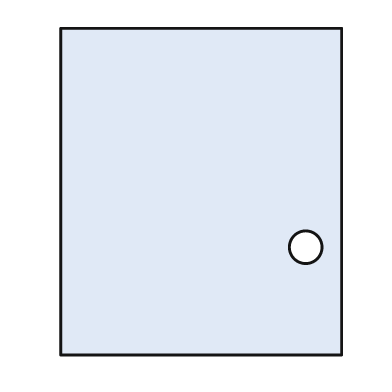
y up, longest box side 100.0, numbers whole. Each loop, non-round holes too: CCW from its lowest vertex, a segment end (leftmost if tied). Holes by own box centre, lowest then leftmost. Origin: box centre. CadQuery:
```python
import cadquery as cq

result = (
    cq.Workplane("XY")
    .moveTo(-43.0, -50.0)
    .lineTo(43.0, -50.0)
    .lineTo(43.0, 50.0)
    .lineTo(-43.0, 50.0)
    .close()
    .moveTo(32.0, -17.0)
    .circle(5.0)
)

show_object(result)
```